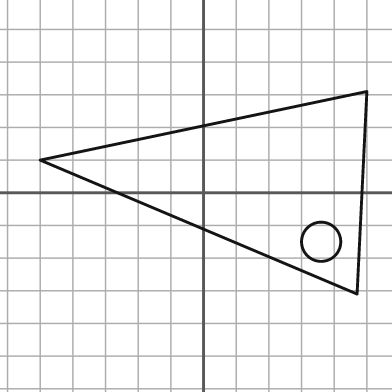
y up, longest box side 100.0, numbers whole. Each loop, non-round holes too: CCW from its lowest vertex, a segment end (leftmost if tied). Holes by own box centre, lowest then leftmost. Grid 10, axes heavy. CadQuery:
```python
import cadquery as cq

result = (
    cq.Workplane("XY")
    .moveTo(47.0, -31.0)
    .lineTo(50.0, 31.0)
    .lineTo(-50.0, 10.0)
    .close()
    .moveTo(36.0, -15.0)
    .circle(6.0)
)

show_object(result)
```